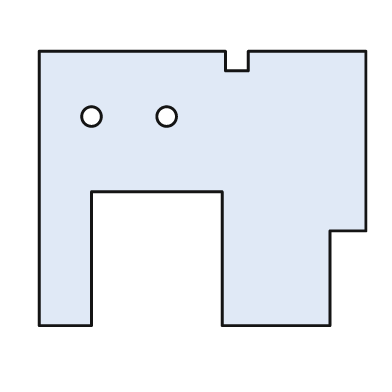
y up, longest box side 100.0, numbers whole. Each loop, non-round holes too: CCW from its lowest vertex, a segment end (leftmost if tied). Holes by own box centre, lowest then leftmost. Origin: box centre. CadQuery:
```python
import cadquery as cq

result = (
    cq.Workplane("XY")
    .moveTo(-50.0, -42.0)
    .lineTo(-34.0, -42.0)
    .lineTo(-34.0, -1.0)
    .lineTo(6.0, -1.0)
    .lineTo(6.0, -42.0)
    .lineTo(39.0, -42.0)
    .lineTo(39.0, -13.0)
    .lineTo(50.0, -13.0)
    .lineTo(50.0, 42.0)
    .lineTo(14.0, 42.0)
    .lineTo(14.0, 36.0)
    .lineTo(7.0, 36.0)
    .lineTo(7.0, 42.0)
    .lineTo(-50.0, 42.0)
    .close()
    .moveTo(-34.0, 22.0)
    .circle(3.0)
    .moveTo(-11.0, 22.0)
    .circle(3.0)
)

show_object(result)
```